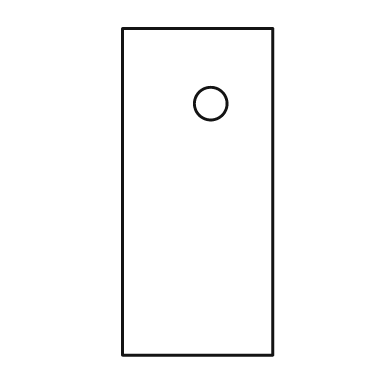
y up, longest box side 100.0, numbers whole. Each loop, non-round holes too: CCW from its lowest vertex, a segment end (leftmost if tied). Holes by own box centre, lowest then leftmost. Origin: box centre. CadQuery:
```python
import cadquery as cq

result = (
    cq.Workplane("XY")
    .moveTo(-23.0, -50.0)
    .lineTo(23.0, -50.0)
    .lineTo(23.0, 50.0)
    .lineTo(-23.0, 50.0)
    .close()
    .moveTo(4.0, 27.0)
    .circle(5.0)
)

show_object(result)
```